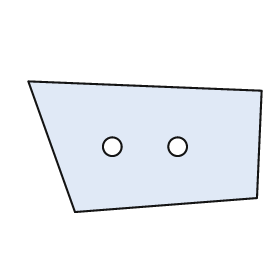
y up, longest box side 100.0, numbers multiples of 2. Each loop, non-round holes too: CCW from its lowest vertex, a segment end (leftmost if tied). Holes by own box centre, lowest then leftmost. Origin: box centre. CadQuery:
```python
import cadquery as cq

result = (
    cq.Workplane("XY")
    .moveTo(-30.0, -28.0)
    .lineTo(48.0, -22.0)
    .lineTo(50.0, 24.0)
    .lineTo(-50.0, 28.0)
    .close()
    .moveTo(-14.0, 0.0)
    .circle(4.0)
    .moveTo(14.0, 0.0)
    .circle(4.0)
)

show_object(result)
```